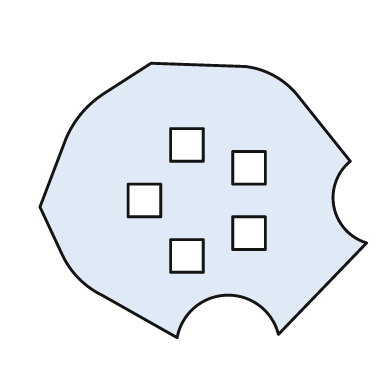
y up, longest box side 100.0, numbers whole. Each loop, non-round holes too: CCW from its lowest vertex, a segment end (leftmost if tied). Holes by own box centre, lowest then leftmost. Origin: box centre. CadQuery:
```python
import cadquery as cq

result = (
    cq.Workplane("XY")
    .moveTo(-8.0, -42.0)
    .threePointArc((7.0, -29.0), (23.0, -41.0))
    .lineTo(50.0, -13.0)
    .threePointArc((40.0, -2.0), (45.0, 12.0))
    .lineTo(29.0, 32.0)
    .threePointArc((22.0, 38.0), (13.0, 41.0))
    .lineTo(-16.0, 42.0)
    .lineTo(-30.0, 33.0)
    .threePointArc((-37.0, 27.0), (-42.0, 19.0))
    .lineTo(-50.0, -2.0)
    .lineTo(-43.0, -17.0)
    .threePointArc((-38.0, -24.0), (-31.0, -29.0))
    .close()
    .moveTo(-10.0, -22.0)
    .lineTo(0.0, -22.0)
    .lineTo(0.0, -12.0)
    .lineTo(-10.0, -12.0)
    .close()
    .moveTo(9.0, -15.0)
    .lineTo(19.0, -15.0)
    .lineTo(19.0, -5.0)
    .lineTo(9.0, -5.0)
    .close()
    .moveTo(-23.0, -5.0)
    .lineTo(-13.0, -5.0)
    .lineTo(-13.0, 5.0)
    .lineTo(-23.0, 5.0)
    .close()
    .moveTo(9.0, 5.0)
    .lineTo(19.0, 5.0)
    .lineTo(19.0, 15.0)
    .lineTo(9.0, 15.0)
    .close()
    .moveTo(-10.0, 12.0)
    .lineTo(0.0, 12.0)
    .lineTo(0.0, 22.0)
    .lineTo(-10.0, 22.0)
    .close()
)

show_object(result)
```